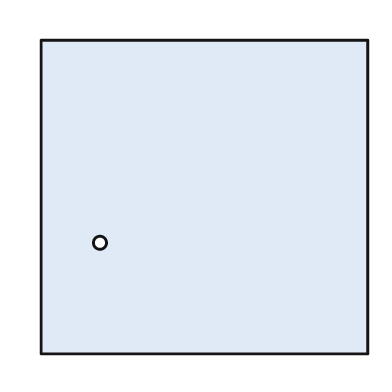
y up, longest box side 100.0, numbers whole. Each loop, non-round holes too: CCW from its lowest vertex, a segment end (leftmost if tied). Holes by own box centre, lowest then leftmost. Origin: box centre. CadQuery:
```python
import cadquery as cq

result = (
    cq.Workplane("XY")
    .moveTo(-50.0, -48.0)
    .lineTo(50.0, -48.0)
    .lineTo(50.0, 48.0)
    .lineTo(-50.0, 48.0)
    .close()
    .moveTo(-32.0, -14.0)
    .circle(2.0)
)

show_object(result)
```